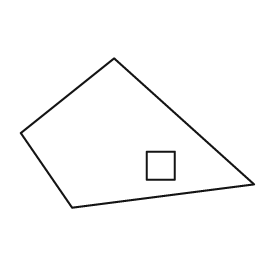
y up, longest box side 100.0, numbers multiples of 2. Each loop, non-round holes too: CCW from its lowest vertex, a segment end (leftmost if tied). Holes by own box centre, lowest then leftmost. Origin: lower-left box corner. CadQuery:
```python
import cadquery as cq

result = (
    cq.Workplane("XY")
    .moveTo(22.0, 0.0)
    .lineTo(100.0, 10.0)
    .lineTo(40.0, 64.0)
    .lineTo(0.0, 32.0)
    .close()
    .moveTo(54.0, 12.0)
    .lineTo(66.0, 12.0)
    .lineTo(66.0, 24.0)
    .lineTo(54.0, 24.0)
    .close()
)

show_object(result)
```